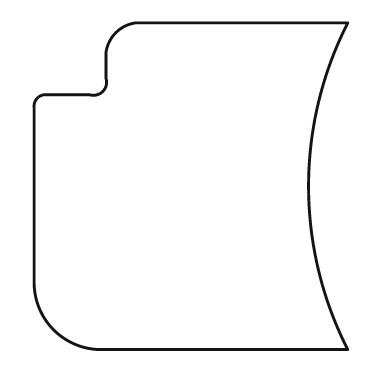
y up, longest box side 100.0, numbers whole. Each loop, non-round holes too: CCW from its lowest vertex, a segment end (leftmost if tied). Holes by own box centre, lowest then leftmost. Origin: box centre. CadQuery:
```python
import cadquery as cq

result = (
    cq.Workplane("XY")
    .moveTo(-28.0, -50.0)
    .lineTo(48.0, -50.0)
    .threePointArc((36.0, 0.0), (48.0, 50.0))
    .lineTo(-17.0, 50.0)
    .threePointArc((-23.0, 47.0), (-26.0, 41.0))
    .lineTo(-26.0, 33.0)
    .threePointArc((-27.0, 29.0), (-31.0, 28.0))
    .lineTo(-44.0, 28.0)
    .threePointArc((-47.0, 27.0), (-48.0, 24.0))
    .lineTo(-48.0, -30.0)
    .threePointArc((-42.0, -44.0), (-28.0, -50.0))
    .close()
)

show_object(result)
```